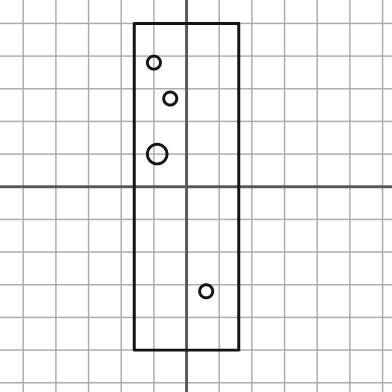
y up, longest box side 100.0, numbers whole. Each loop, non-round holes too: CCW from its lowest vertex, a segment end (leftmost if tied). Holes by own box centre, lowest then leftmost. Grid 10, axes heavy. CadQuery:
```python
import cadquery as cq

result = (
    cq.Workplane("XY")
    .moveTo(-16.0, -50.0)
    .lineTo(16.0, -50.0)
    .lineTo(16.0, 50.0)
    .lineTo(-16.0, 50.0)
    .close()
    .moveTo(6.0, -32.0)
    .circle(2.0)
    .moveTo(-9.0, 10.0)
    .circle(3.0)
    .moveTo(-5.0, 27.0)
    .circle(2.0)
    .moveTo(-10.0, 38.0)
    .circle(2.0)
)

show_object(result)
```